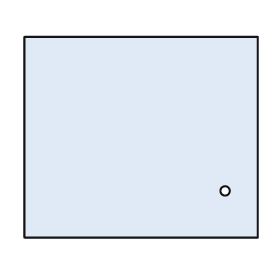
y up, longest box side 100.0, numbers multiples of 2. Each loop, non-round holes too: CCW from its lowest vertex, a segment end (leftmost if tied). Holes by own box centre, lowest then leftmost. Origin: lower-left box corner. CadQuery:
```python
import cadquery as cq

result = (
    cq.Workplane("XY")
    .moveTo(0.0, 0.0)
    .lineTo(100.0, 0.0)
    .lineTo(100.0, 86.0)
    .lineTo(0.0, 86.0)
    .close()
    .moveTo(86.0, 20.0)
    .circle(2.0)
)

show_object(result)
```